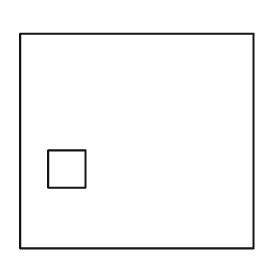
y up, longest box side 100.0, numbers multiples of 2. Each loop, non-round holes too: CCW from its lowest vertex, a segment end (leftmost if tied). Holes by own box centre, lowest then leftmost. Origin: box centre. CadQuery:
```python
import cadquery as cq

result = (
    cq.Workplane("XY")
    .moveTo(-50.0, -46.0)
    .lineTo(50.0, -46.0)
    .lineTo(50.0, 46.0)
    .lineTo(-50.0, 46.0)
    .close()
    .moveTo(-38.0, -20.0)
    .lineTo(-22.0, -20.0)
    .lineTo(-22.0, -4.0)
    .lineTo(-38.0, -4.0)
    .close()
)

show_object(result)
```